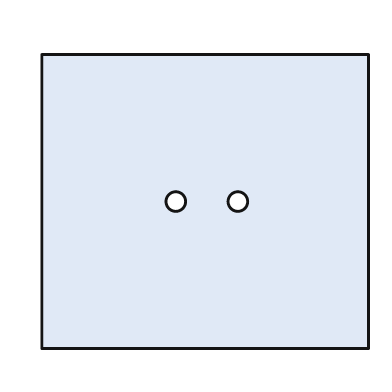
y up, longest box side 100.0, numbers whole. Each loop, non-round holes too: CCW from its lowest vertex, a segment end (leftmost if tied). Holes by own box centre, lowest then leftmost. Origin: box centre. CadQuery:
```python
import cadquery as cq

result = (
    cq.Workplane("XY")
    .moveTo(-50.0, -45.0)
    .lineTo(50.0, -45.0)
    .lineTo(50.0, 45.0)
    .lineTo(-50.0, 45.0)
    .close()
    .moveTo(-9.0, 0.0)
    .circle(3.0)
    .moveTo(10.0, 0.0)
    .circle(3.0)
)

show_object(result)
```